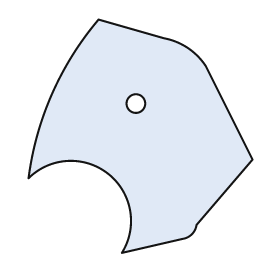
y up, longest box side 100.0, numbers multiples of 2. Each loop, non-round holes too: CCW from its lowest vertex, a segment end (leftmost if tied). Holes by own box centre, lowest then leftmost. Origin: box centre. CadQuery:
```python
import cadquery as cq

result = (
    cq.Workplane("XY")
    .moveTo(-8.0, -50.0)
    .lineTo(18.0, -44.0)
    .threePointArc((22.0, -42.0), (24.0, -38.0))
    .lineTo(48.0, -10.0)
    .lineTo(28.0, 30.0)
    .threePointArc((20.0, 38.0), (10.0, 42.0))
    .lineTo(-18.0, 50.0)
    .threePointArc((-38.0, 18.0), (-48.0, -18.0))
    .threePointArc((-14.0, -16.0), (-8.0, -50.0))
    .close()
    .moveTo(-2.0, 14.0)
    .circle(4.0)
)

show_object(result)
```